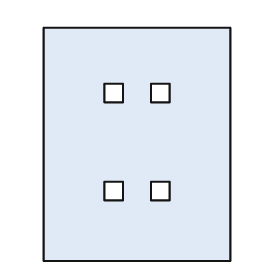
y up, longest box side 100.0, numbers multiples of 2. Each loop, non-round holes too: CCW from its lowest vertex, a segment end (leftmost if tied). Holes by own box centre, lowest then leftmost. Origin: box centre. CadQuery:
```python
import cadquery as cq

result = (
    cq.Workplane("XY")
    .moveTo(-40.0, -50.0)
    .lineTo(40.0, -50.0)
    .lineTo(40.0, 50.0)
    .lineTo(-40.0, 50.0)
    .close()
    .moveTo(-14.0, -24.0)
    .lineTo(-6.0, -24.0)
    .lineTo(-6.0, -16.0)
    .lineTo(-14.0, -16.0)
    .close()
    .moveTo(6.0, -24.0)
    .lineTo(14.0, -24.0)
    .lineTo(14.0, -16.0)
    .lineTo(6.0, -16.0)
    .close()
    .moveTo(-14.0, 18.0)
    .lineTo(-6.0, 18.0)
    .lineTo(-6.0, 26.0)
    .lineTo(-14.0, 26.0)
    .close()
    .moveTo(6.0, 18.0)
    .lineTo(14.0, 18.0)
    .lineTo(14.0, 26.0)
    .lineTo(6.0, 26.0)
    .close()
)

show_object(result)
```